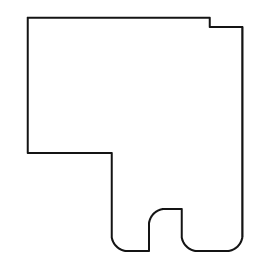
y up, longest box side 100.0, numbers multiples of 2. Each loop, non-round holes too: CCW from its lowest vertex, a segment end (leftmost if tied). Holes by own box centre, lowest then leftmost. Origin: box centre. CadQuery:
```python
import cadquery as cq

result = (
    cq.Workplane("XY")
    .moveTo(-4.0, -50.0)
    .lineTo(6.0, -50.0)
    .lineTo(6.0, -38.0)
    .threePointArc((8.0, -34.0), (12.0, -32.0))
    .lineTo(20.0, -32.0)
    .lineTo(20.0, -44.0)
    .threePointArc((22.0, -48.0), (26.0, -50.0))
    .lineTo(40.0, -50.0)
    .threePointArc((44.0, -48.0), (46.0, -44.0))
    .lineTo(46.0, 46.0)
    .lineTo(32.0, 46.0)
    .lineTo(32.0, 50.0)
    .lineTo(-46.0, 50.0)
    .lineTo(-46.0, -8.0)
    .lineTo(-10.0, -8.0)
    .lineTo(-10.0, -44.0)
    .threePointArc((-8.0, -48.0), (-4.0, -50.0))
    .close()
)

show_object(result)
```